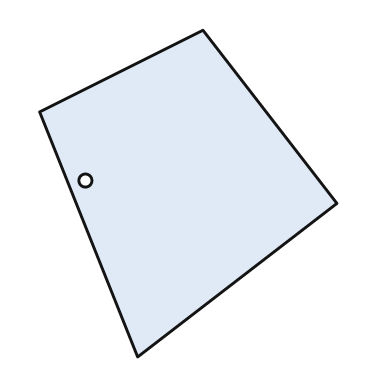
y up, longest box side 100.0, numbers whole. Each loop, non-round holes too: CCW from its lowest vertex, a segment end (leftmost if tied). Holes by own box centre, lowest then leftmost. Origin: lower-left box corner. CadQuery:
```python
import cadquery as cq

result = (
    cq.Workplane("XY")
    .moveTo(30.0, 0.0)
    .lineTo(91.0, 47.0)
    .lineTo(50.0, 100.0)
    .lineTo(0.0, 75.0)
    .close()
    .moveTo(14.0, 54.0)
    .circle(2.0)
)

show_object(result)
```